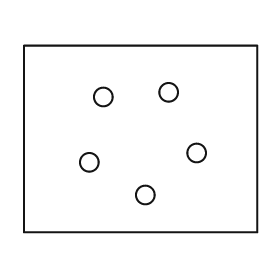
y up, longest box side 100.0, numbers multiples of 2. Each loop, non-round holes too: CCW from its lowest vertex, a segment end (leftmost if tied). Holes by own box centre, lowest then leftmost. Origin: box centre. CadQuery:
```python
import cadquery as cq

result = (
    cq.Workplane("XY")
    .moveTo(-50.0, -40.0)
    .lineTo(50.0, -40.0)
    .lineTo(50.0, 40.0)
    .lineTo(-50.0, 40.0)
    .close()
    .moveTo(2.0, -24.0)
    .circle(4.0)
    .moveTo(-22.0, -10.0)
    .circle(4.0)
    .moveTo(24.0, -6.0)
    .circle(4.0)
    .moveTo(-16.0, 18.0)
    .circle(4.0)
    .moveTo(12.0, 20.0)
    .circle(4.0)
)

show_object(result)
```